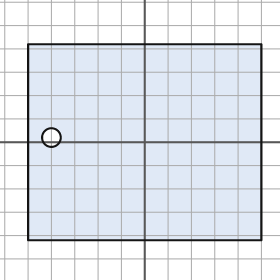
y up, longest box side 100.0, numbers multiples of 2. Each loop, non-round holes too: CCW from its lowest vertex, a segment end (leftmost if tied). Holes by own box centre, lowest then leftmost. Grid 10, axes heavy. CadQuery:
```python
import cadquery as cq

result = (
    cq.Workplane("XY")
    .moveTo(-50.0, -42.0)
    .lineTo(50.0, -42.0)
    .lineTo(50.0, 42.0)
    .lineTo(-50.0, 42.0)
    .close()
    .moveTo(-40.0, 2.0)
    .circle(4.0)
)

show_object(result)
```